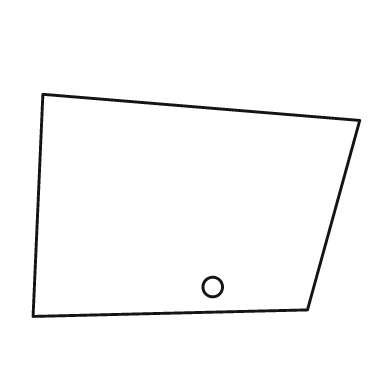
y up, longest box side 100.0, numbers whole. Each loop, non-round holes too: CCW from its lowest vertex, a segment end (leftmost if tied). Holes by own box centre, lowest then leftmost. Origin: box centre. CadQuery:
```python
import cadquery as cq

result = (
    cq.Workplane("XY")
    .moveTo(-50.0, -34.0)
    .lineTo(34.0, -32.0)
    .lineTo(50.0, 26.0)
    .lineTo(-47.0, 34.0)
    .close()
    .moveTo(5.0, -25.0)
    .circle(3.0)
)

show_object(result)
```